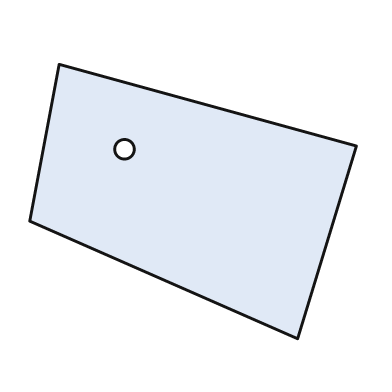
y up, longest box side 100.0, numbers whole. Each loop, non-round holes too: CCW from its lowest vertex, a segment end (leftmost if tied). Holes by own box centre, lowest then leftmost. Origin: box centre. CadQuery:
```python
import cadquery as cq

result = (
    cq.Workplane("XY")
    .moveTo(32.0, -42.0)
    .lineTo(50.0, 17.0)
    .lineTo(-41.0, 42.0)
    .lineTo(-50.0, -6.0)
    .close()
    .moveTo(-21.0, 16.0)
    .circle(3.0)
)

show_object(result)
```